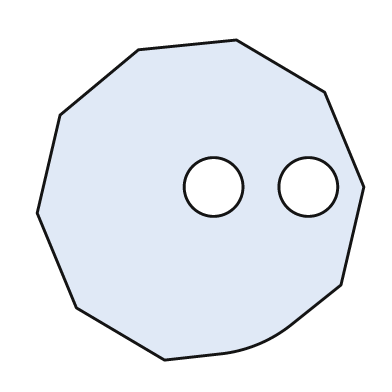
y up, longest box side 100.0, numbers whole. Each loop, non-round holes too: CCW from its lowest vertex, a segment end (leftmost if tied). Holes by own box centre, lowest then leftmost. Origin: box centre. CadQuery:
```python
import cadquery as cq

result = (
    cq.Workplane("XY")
    .moveTo(-11.0, -49.0)
    .lineTo(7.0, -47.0)
    .threePointArc((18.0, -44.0), (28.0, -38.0))
    .lineTo(43.0, -26.0)
    .lineTo(50.0, 4.0)
    .lineTo(38.0, 33.0)
    .lineTo(11.0, 49.0)
    .lineTo(-19.0, 46.0)
    .lineTo(-43.0, 26.0)
    .lineTo(-50.0, -4.0)
    .lineTo(-38.0, -33.0)
    .close()
    .moveTo(4.0, 4.0)
    .circle(9.0)
    .moveTo(33.0, 4.0)
    .circle(9.0)
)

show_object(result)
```